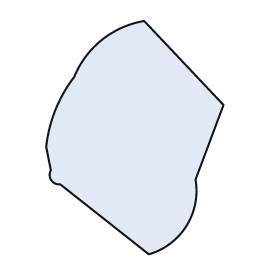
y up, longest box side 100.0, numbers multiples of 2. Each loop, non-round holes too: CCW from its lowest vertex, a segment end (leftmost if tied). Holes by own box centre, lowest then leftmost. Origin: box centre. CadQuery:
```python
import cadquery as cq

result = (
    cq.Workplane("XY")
    .moveTo(6.0, -50.0)
    .threePointArc((22.0, -38.0), (26.0, -18.0))
    .lineTo(38.0, 14.0)
    .lineTo(4.0, 50.0)
    .threePointArc((-14.0, 42.0), (-26.0, 26.0))
    .threePointArc((-34.0, 12.0), (-38.0, -4.0))
    .lineTo(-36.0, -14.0)
    .threePointArc((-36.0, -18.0), (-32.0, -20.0))
    .close()
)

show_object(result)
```